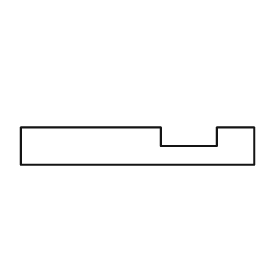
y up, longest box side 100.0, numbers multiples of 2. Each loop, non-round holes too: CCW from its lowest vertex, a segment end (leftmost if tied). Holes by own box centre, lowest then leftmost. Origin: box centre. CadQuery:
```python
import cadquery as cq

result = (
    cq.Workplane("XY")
    .moveTo(-50.0, -8.0)
    .lineTo(50.0, -8.0)
    .lineTo(50.0, 8.0)
    .lineTo(34.0, 8.0)
    .lineTo(34.0, 0.0)
    .lineTo(10.0, 0.0)
    .lineTo(10.0, 8.0)
    .lineTo(-50.0, 8.0)
    .close()
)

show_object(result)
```